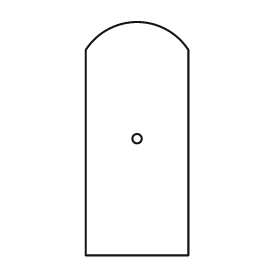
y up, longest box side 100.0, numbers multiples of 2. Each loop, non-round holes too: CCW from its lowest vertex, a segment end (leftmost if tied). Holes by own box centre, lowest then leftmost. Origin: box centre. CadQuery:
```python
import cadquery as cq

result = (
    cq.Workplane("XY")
    .moveTo(-22.0, -50.0)
    .lineTo(22.0, -50.0)
    .lineTo(22.0, 38.0)
    .threePointArc((0.0, 50.0), (-22.0, 38.0))
    .close()
    .moveTo(0.0, 0.0)
    .circle(2.0)
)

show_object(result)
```